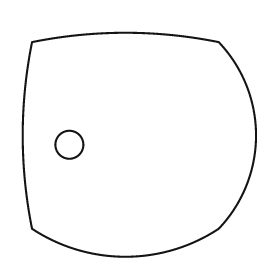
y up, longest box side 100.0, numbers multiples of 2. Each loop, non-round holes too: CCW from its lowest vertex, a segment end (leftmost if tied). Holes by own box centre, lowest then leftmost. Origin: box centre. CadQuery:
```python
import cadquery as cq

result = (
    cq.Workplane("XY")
    .moveTo(-46.0, -36.0)
    .threePointArc((-6.0, -48.0), (34.0, -36.0))
    .threePointArc((50.0, 4.0), (34.0, 44.0))
    .threePointArc((-6.0, 48.0), (-46.0, 44.0))
    .threePointArc((-50.0, 4.0), (-46.0, -36.0))
    .close()
    .moveTo(-30.0, 0.0)
    .circle(6.0)
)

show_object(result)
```